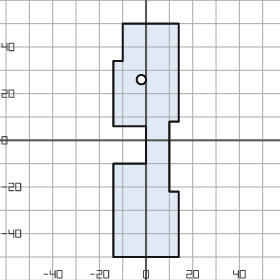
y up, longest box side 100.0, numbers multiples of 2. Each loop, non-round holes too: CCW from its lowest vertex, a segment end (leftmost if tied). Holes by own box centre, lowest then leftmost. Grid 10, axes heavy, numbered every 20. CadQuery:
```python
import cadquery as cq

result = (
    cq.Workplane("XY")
    .moveTo(-14.0, -50.0)
    .lineTo(14.0, -50.0)
    .lineTo(14.0, -22.0)
    .lineTo(10.0, -22.0)
    .lineTo(10.0, 8.0)
    .lineTo(14.0, 8.0)
    .lineTo(14.0, 50.0)
    .lineTo(-10.0, 50.0)
    .lineTo(-10.0, 34.0)
    .lineTo(-14.0, 34.0)
    .lineTo(-14.0, 6.0)
    .lineTo(0.0, 6.0)
    .lineTo(0.0, -10.0)
    .lineTo(-14.0, -10.0)
    .close()
    .moveTo(-2.0, 26.0)
    .circle(2.0)
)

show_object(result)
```